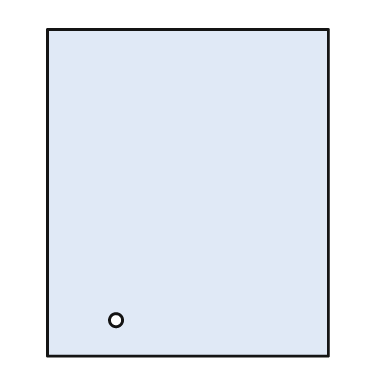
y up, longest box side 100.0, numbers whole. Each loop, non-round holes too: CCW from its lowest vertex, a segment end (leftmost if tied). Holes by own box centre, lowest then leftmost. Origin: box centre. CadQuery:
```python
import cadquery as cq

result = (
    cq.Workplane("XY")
    .moveTo(-43.0, -50.0)
    .lineTo(43.0, -50.0)
    .lineTo(43.0, 50.0)
    .lineTo(-43.0, 50.0)
    .close()
    .moveTo(-22.0, -39.0)
    .circle(2.0)
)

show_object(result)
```